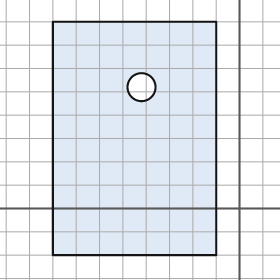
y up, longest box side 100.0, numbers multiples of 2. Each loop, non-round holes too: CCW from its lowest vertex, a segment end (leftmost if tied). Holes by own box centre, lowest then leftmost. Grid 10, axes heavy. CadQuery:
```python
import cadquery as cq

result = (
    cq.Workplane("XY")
    .moveTo(-80.0, -20.0)
    .lineTo(-10.0, -20.0)
    .lineTo(-10.0, 80.0)
    .lineTo(-80.0, 80.0)
    .close()
    .moveTo(-42.0, 52.0)
    .circle(6.0)
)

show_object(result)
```